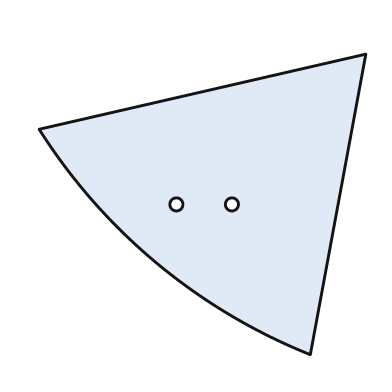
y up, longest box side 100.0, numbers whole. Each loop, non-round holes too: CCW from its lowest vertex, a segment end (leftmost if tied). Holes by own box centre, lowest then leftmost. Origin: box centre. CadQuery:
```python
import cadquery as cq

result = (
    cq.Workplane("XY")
    .moveTo(33.0, -46.0)
    .lineTo(50.0, 46.0)
    .lineTo(-50.0, 23.0)
    .threePointArc((-14.0, -18.0), (33.0, -46.0))
    .close()
    .moveTo(-8.0, 0.0)
    .circle(2.0)
    .moveTo(9.0, 0.0)
    .circle(2.0)
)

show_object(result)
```